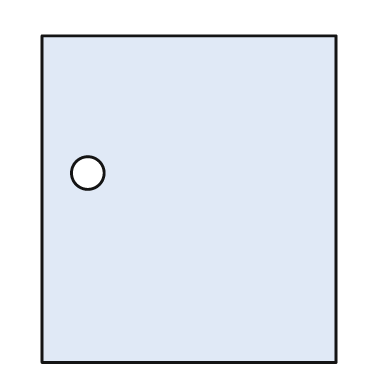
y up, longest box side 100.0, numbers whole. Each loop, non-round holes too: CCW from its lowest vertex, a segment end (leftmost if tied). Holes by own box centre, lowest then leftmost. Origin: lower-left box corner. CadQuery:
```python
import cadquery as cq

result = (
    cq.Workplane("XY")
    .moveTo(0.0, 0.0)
    .lineTo(90.0, 0.0)
    .lineTo(90.0, 100.0)
    .lineTo(0.0, 100.0)
    .close()
    .moveTo(14.0, 58.0)
    .circle(5.0)
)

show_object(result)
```